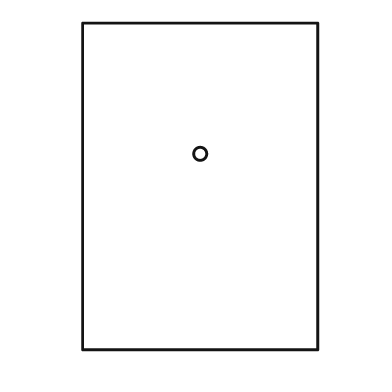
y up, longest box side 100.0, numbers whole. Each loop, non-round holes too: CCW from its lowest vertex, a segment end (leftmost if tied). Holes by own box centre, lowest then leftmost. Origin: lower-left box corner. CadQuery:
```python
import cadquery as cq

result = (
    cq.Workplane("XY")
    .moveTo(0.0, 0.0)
    .lineTo(72.0, 0.0)
    .lineTo(72.0, 100.0)
    .lineTo(0.0, 100.0)
    .close()
    .moveTo(36.0, 60.0)
    .circle(2.0)
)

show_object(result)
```